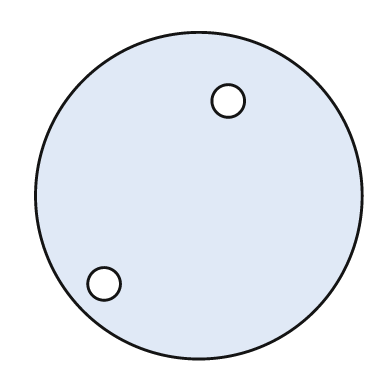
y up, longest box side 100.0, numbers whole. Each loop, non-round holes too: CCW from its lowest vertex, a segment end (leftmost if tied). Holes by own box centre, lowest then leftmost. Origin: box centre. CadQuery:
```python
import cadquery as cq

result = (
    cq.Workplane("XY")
    .moveTo(0.0, 0.0)
    .circle(50.0)
    .moveTo(-29.0, -27.0)
    .circle(5.0)
    .moveTo(9.0, 29.0)
    .circle(5.0)
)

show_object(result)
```